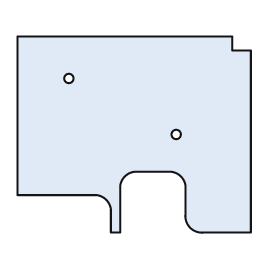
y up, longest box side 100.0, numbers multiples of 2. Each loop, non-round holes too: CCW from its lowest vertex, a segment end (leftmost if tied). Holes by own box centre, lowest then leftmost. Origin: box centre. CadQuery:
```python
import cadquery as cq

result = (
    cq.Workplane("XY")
    .moveTo(-10.0, -42.0)
    .lineTo(-6.0, -42.0)
    .lineTo(-6.0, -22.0)
    .threePointArc((-4.0, -18.0), (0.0, -16.0))
    .lineTo(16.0, -16.0)
    .threePointArc((20.0, -18.0), (22.0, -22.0))
    .lineTo(22.0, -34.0)
    .threePointArc((24.0, -40.0), (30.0, -42.0))
    .lineTo(50.0, -42.0)
    .lineTo(50.0, 36.0)
    .lineTo(42.0, 36.0)
    .lineTo(42.0, 42.0)
    .lineTo(-50.0, 42.0)
    .lineTo(-50.0, -26.0)
    .lineTo(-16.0, -26.0)
    .threePointArc((-12.0, -28.0), (-10.0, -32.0))
    .close()
    .moveTo(18.0, 0.0)
    .circle(2.0)
    .moveTo(-28.0, 24.0)
    .circle(2.0)
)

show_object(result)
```